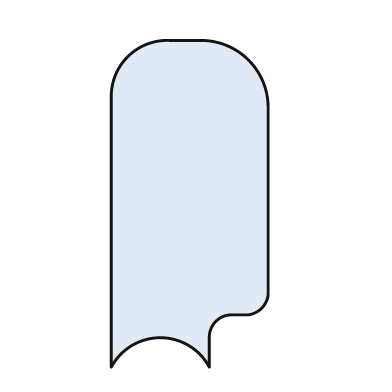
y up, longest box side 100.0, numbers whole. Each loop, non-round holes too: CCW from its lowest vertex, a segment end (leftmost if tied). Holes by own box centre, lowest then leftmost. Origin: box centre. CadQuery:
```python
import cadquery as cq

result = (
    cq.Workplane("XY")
    .moveTo(-24.0, -50.0)
    .threePointArc((-9.0, -41.0), (6.0, -50.0))
    .lineTo(6.0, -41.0)
    .threePointArc((8.0, -36.0), (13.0, -34.0))
    .lineTo(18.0, -34.0)
    .threePointArc((22.0, -32.0), (24.0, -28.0))
    .lineTo(24.0, 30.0)
    .threePointArc((18.0, 44.0), (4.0, 50.0))
    .lineTo(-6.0, 50.0)
    .threePointArc((-19.0, 45.0), (-24.0, 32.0))
    .close()
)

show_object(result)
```